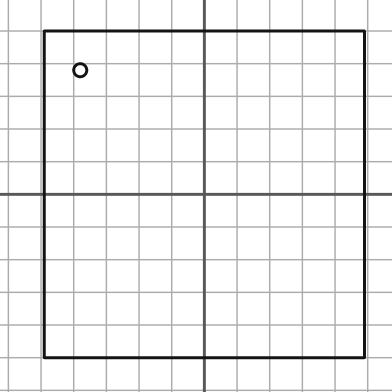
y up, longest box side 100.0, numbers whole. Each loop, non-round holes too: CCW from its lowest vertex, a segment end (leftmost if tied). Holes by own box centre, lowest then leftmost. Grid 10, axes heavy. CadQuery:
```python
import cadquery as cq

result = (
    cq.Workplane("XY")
    .moveTo(-49.0, -50.0)
    .lineTo(49.0, -50.0)
    .lineTo(49.0, 50.0)
    .lineTo(-49.0, 50.0)
    .close()
    .moveTo(-38.0, 38.0)
    .circle(2.0)
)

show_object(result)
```